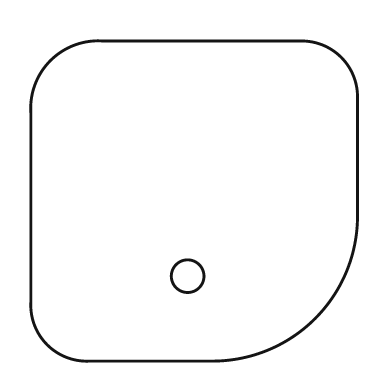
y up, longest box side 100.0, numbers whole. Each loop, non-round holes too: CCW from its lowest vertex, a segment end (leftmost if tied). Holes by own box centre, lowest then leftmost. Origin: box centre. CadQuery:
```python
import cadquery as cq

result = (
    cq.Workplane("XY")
    .moveTo(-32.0, -49.0)
    .lineTo(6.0, -49.0)
    .threePointArc((37.0, -36.0), (50.0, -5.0))
    .lineTo(50.0, 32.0)
    .threePointArc((45.0, 44.0), (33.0, 49.0))
    .lineTo(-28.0, 49.0)
    .threePointArc((-44.0, 43.0), (-50.0, 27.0))
    .lineTo(-50.0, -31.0)
    .threePointArc((-45.0, -44.0), (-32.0, -49.0))
    .close()
    .moveTo(-2.0, -23.0)
    .circle(5.0)
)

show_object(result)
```